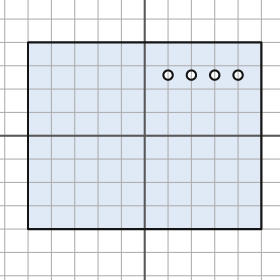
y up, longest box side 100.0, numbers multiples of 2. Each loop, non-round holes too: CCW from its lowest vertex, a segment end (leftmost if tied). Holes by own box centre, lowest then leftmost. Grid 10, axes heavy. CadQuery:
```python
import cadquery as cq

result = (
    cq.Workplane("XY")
    .moveTo(-50.0, -40.0)
    .lineTo(50.0, -40.0)
    .lineTo(50.0, 40.0)
    .lineTo(-50.0, 40.0)
    .close()
    .moveTo(10.0, 26.0)
    .circle(2.0)
    .moveTo(20.0, 26.0)
    .circle(2.0)
    .moveTo(30.0, 26.0)
    .circle(2.0)
    .moveTo(40.0, 26.0)
    .circle(2.0)
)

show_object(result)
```